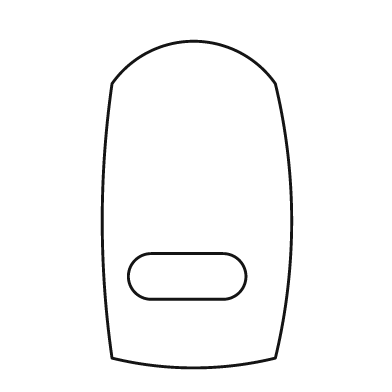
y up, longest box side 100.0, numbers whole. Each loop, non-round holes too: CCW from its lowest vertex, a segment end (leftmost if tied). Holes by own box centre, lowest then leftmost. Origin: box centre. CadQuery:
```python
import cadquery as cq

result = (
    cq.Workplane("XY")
    .moveTo(-26.0, -47.0)
    .threePointArc((-1.0, -50.0), (24.0, -47.0))
    .threePointArc((29.0, -5.0), (24.0, 37.0))
    .threePointArc((-1.0, 50.0), (-26.0, 37.0))
    .threePointArc((-29.0, -5.0), (-26.0, -47.0))
    .close()
    .moveTo(-14.0, -29.0)
    .lineTo(8.0, -29.0)
    .threePointArc((15.0, -22.0), (8.0, -15.0))
    .lineTo(-14.0, -15.0)
    .threePointArc((-21.0, -22.0), (-14.0, -29.0))
    .close()
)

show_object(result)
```